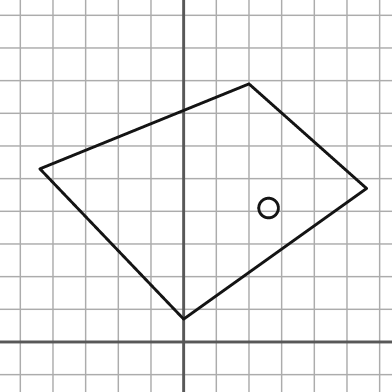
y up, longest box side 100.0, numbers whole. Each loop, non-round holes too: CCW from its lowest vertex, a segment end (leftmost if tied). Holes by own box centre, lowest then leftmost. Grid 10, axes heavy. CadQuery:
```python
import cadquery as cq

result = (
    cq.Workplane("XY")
    .moveTo(0.0, 7.0)
    .lineTo(56.0, 47.0)
    .lineTo(20.0, 79.0)
    .lineTo(-44.0, 53.0)
    .close()
    .moveTo(26.0, 41.0)
    .circle(3.0)
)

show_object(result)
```